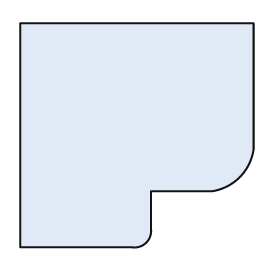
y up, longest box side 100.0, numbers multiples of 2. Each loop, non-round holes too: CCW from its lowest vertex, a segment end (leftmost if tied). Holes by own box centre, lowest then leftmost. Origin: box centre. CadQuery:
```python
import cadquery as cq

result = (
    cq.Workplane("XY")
    .moveTo(-50.0, -48.0)
    .lineTo(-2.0, -48.0)
    .threePointArc((4.0, -46.0), (6.0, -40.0))
    .lineTo(6.0, -24.0)
    .lineTo(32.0, -24.0)
    .threePointArc((44.0, -18.0), (50.0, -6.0))
    .lineTo(50.0, 48.0)
    .lineTo(-50.0, 48.0)
    .close()
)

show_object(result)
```